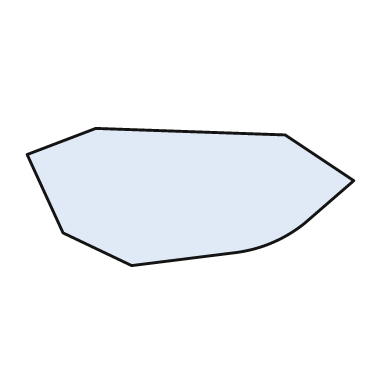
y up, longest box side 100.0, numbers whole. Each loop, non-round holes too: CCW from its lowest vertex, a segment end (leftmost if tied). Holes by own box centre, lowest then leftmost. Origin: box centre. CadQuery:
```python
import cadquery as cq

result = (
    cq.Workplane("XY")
    .moveTo(-18.0, -21.0)
    .lineTo(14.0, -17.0)
    .threePointArc((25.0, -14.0), (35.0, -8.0))
    .lineTo(50.0, 5.0)
    .lineTo(29.0, 19.0)
    .lineTo(-29.0, 21.0)
    .lineTo(-50.0, 13.0)
    .lineTo(-39.0, -11.0)
    .close()
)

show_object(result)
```